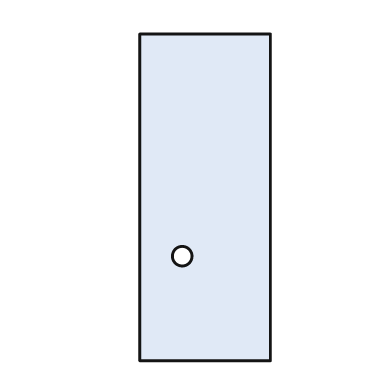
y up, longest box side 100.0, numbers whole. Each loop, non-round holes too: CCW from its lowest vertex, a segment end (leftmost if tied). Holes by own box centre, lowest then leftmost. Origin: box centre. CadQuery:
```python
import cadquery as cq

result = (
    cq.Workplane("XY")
    .moveTo(-20.0, -50.0)
    .lineTo(20.0, -50.0)
    .lineTo(20.0, 50.0)
    .lineTo(-20.0, 50.0)
    .close()
    .moveTo(-7.0, -18.0)
    .circle(3.0)
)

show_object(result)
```